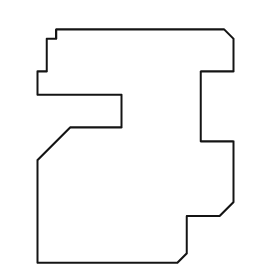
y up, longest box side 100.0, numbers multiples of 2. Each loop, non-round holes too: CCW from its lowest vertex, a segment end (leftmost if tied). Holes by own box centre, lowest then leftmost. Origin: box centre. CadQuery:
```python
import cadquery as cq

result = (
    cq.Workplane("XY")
    .moveTo(-42.0, -50.0)
    .lineTo(18.0, -50.0)
    .lineTo(22.0, -46.0)
    .lineTo(22.0, -30.0)
    .lineTo(36.0, -30.0)
    .lineTo(42.0, -24.0)
    .lineTo(42.0, 2.0)
    .lineTo(28.0, 2.0)
    .lineTo(28.0, 32.0)
    .lineTo(42.0, 32.0)
    .lineTo(42.0, 46.0)
    .lineTo(38.0, 50.0)
    .lineTo(-34.0, 50.0)
    .lineTo(-34.0, 46.0)
    .lineTo(-38.0, 46.0)
    .lineTo(-38.0, 32.0)
    .lineTo(-42.0, 32.0)
    .lineTo(-42.0, 22.0)
    .lineTo(-6.0, 22.0)
    .lineTo(-6.0, 8.0)
    .lineTo(-28.0, 8.0)
    .lineTo(-42.0, -6.0)
    .close()
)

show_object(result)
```